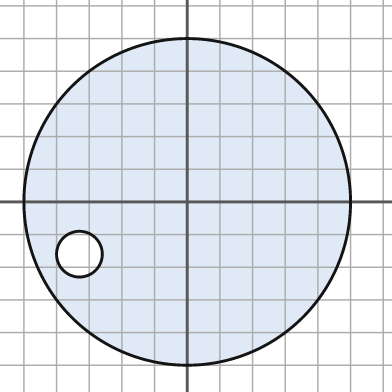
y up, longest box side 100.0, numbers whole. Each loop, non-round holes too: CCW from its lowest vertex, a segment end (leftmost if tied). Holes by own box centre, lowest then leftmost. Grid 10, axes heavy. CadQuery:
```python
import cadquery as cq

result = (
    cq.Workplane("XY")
    .moveTo(0.0, 0.0)
    .circle(50.0)
    .moveTo(-33.0, -16.0)
    .circle(7.0)
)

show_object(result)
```